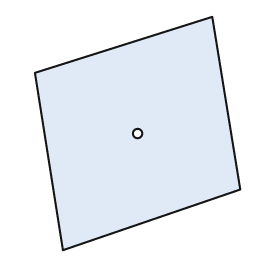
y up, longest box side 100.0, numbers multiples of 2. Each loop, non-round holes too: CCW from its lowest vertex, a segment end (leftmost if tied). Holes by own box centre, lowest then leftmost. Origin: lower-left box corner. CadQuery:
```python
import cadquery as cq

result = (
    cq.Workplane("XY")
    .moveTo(12.0, 0.0)
    .lineTo(88.0, 26.0)
    .lineTo(76.0, 100.0)
    .lineTo(0.0, 76.0)
    .close()
    .moveTo(44.0, 50.0)
    .circle(2.0)
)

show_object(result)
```